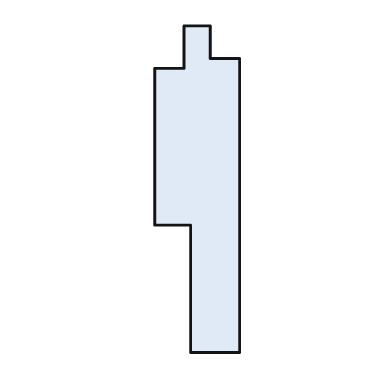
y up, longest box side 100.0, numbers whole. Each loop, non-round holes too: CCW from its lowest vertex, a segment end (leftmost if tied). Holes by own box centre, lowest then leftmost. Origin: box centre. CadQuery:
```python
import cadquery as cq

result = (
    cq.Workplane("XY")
    .moveTo(-2.0, -50.0)
    .lineTo(13.0, -50.0)
    .lineTo(13.0, 40.0)
    .lineTo(4.0, 40.0)
    .lineTo(4.0, 50.0)
    .lineTo(-4.0, 50.0)
    .lineTo(-4.0, 37.0)
    .lineTo(-13.0, 37.0)
    .lineTo(-13.0, -11.0)
    .lineTo(-2.0, -11.0)
    .close()
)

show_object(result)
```